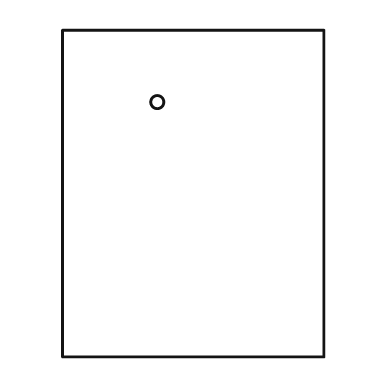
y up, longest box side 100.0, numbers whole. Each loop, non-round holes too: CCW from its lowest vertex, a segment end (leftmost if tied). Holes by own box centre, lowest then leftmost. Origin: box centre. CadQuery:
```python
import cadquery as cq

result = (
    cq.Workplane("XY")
    .moveTo(-40.0, -50.0)
    .lineTo(40.0, -50.0)
    .lineTo(40.0, 50.0)
    .lineTo(-40.0, 50.0)
    .close()
    .moveTo(-11.0, 28.0)
    .circle(2.0)
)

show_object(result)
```